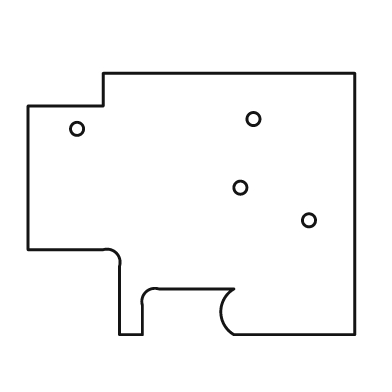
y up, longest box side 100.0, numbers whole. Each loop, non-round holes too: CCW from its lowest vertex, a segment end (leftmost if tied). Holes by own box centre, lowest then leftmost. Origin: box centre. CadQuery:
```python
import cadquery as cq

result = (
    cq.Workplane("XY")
    .moveTo(-22.0, -40.0)
    .lineTo(-15.0, -40.0)
    .lineTo(-15.0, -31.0)
    .threePointArc((-14.0, -27.0), (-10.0, -26.0))
    .lineTo(13.0, -26.0)
    .threePointArc((9.0, -33.0), (13.0, -40.0))
    .lineTo(50.0, -40.0)
    .lineTo(50.0, 40.0)
    .lineTo(-27.0, 40.0)
    .lineTo(-27.0, 30.0)
    .lineTo(-50.0, 30.0)
    .lineTo(-50.0, -14.0)
    .lineTo(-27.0, -14.0)
    .threePointArc((-23.0, -15.0), (-22.0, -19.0))
    .close()
    .moveTo(36.0, -5.0)
    .circle(2.0)
    .moveTo(15.0, 5.0)
    .circle(2.0)
    .moveTo(-35.0, 23.0)
    .circle(2.0)
    .moveTo(19.0, 26.0)
    .circle(2.0)
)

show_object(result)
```